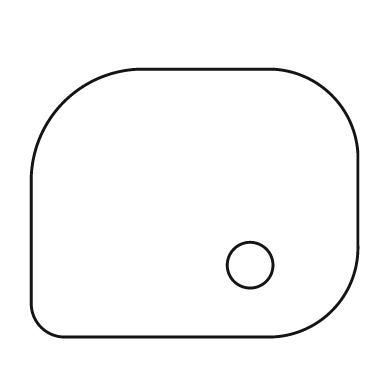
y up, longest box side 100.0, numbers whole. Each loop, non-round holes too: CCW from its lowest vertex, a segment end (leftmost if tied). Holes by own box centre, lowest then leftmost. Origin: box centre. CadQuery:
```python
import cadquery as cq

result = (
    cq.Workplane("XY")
    .moveTo(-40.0, -41.0)
    .lineTo(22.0, -41.0)
    .threePointArc((42.0, -33.0), (50.0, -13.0))
    .lineTo(50.0, 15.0)
    .threePointArc((42.0, 33.0), (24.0, 41.0))
    .lineTo(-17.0, 41.0)
    .threePointArc((-40.0, 31.0), (-50.0, 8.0))
    .lineTo(-50.0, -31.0)
    .threePointArc((-47.0, -38.0), (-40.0, -41.0))
    .close()
    .moveTo(17.0, -19.0)
    .circle(7.0)
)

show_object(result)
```